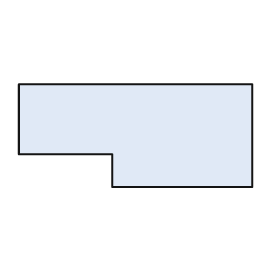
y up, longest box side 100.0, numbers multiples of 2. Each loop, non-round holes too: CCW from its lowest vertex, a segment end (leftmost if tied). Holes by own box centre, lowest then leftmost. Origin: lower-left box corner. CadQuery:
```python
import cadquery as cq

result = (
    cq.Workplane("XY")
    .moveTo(40.0, 0.0)
    .lineTo(100.0, 0.0)
    .lineTo(100.0, 44.0)
    .lineTo(0.0, 44.0)
    .lineTo(0.0, 14.0)
    .lineTo(40.0, 14.0)
    .close()
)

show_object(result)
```